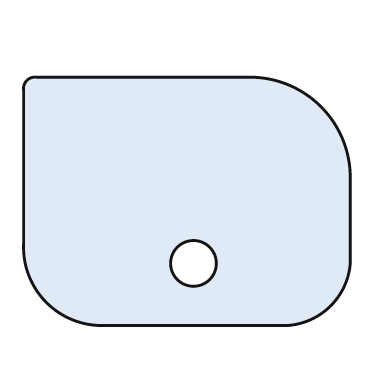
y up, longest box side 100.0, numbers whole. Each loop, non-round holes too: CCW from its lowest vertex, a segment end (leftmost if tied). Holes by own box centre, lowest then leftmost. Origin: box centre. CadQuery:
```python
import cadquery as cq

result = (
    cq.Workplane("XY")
    .moveTo(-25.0, -38.0)
    .lineTo(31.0, -38.0)
    .threePointArc((44.0, -32.0), (50.0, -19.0))
    .lineTo(50.0, 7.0)
    .threePointArc((41.0, 29.0), (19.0, 38.0))
    .lineTo(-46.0, 38.0)
    .threePointArc((-49.0, 37.0), (-50.0, 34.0))
    .lineTo(-50.0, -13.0)
    .threePointArc((-43.0, -31.0), (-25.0, -38.0))
    .close()
    .moveTo(2.0, -19.0)
    .circle(7.0)
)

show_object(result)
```